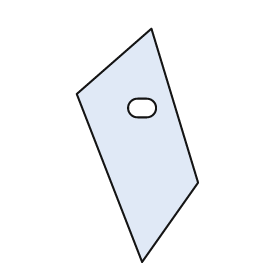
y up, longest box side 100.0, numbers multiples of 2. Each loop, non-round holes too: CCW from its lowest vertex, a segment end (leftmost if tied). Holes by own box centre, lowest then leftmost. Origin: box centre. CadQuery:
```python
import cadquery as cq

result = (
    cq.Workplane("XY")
    .moveTo(2.0, -50.0)
    .lineTo(26.0, -16.0)
    .lineTo(6.0, 50.0)
    .lineTo(-26.0, 22.0)
    .close()
    .moveTo(0.0, 12.0)
    .lineTo(4.0, 12.0)
    .threePointArc((8.0, 16.0), (4.0, 20.0))
    .lineTo(0.0, 20.0)
    .threePointArc((-4.0, 16.0), (0.0, 12.0))
    .close()
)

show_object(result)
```